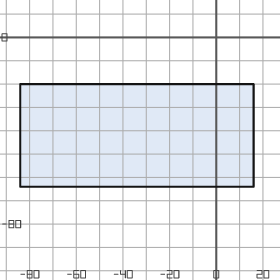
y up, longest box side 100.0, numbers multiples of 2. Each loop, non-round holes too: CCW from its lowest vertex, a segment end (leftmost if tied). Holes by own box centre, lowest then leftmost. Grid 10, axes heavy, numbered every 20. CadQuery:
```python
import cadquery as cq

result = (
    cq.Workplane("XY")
    .moveTo(-84.0, -64.0)
    .lineTo(16.0, -64.0)
    .lineTo(16.0, -20.0)
    .lineTo(-84.0, -20.0)
    .close()
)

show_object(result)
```